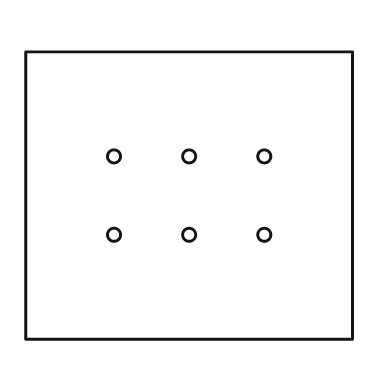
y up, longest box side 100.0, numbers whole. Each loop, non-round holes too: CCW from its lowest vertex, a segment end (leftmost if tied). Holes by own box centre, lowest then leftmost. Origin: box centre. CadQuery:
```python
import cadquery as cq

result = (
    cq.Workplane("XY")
    .moveTo(-50.0, -44.0)
    .lineTo(50.0, -44.0)
    .lineTo(50.0, 44.0)
    .lineTo(-50.0, 44.0)
    .close()
    .moveTo(-23.0, -12.0)
    .circle(2.0)
    .moveTo(0.0, -12.0)
    .circle(2.0)
    .moveTo(23.0, -12.0)
    .circle(2.0)
    .moveTo(-23.0, 12.0)
    .circle(2.0)
    .moveTo(0.0, 12.0)
    .circle(2.0)
    .moveTo(23.0, 12.0)
    .circle(2.0)
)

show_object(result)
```